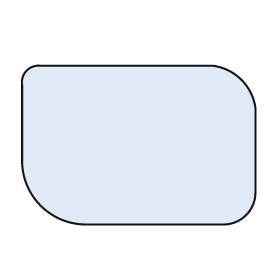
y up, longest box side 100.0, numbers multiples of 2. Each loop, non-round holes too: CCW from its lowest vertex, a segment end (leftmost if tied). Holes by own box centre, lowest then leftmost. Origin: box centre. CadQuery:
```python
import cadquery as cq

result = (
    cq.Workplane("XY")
    .moveTo(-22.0, -34.0)
    .lineTo(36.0, -34.0)
    .threePointArc((46.0, -30.0), (50.0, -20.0))
    .lineTo(50.0, 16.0)
    .threePointArc((44.0, 28.0), (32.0, 34.0))
    .lineTo(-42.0, 34.0)
    .threePointArc((-48.0, 32.0), (-50.0, 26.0))
    .lineTo(-50.0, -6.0)
    .threePointArc((-42.0, -26.0), (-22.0, -34.0))
    .close()
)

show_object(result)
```